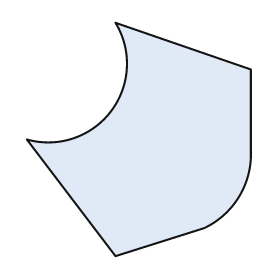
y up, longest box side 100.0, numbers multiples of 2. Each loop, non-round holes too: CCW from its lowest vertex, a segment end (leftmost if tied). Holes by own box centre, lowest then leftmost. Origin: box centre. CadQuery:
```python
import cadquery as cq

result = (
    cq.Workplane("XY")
    .moveTo(-10.0, -50.0)
    .lineTo(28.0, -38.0)
    .threePointArc((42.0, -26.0), (48.0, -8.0))
    .lineTo(48.0, 30.0)
    .lineTo(-10.0, 50.0)
    .threePointArc((-12.0, 12.0), (-48.0, 0.0))
    .close()
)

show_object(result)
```